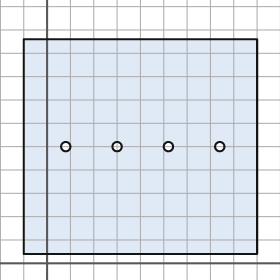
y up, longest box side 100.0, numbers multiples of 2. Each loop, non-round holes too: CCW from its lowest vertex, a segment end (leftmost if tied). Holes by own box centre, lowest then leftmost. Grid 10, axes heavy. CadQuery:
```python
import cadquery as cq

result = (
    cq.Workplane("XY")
    .moveTo(-10.0, 4.0)
    .lineTo(90.0, 4.0)
    .lineTo(90.0, 96.0)
    .lineTo(-10.0, 96.0)
    .close()
    .moveTo(8.0, 50.0)
    .circle(2.0)
    .moveTo(30.0, 50.0)
    .circle(2.0)
    .moveTo(52.0, 50.0)
    .circle(2.0)
    .moveTo(74.0, 50.0)
    .circle(2.0)
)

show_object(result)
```